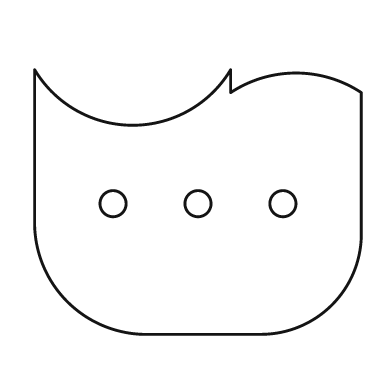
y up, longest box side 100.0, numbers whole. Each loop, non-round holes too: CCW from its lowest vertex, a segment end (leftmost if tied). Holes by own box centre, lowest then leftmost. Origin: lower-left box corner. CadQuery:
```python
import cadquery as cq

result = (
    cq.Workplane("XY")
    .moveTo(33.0, 0.0)
    .lineTo(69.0, 0.0)
    .threePointArc((91.0, 9.0), (100.0, 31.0))
    .lineTo(100.0, 74.0)
    .threePointArc((80.0, 80.0), (60.0, 74.0))
    .lineTo(60.0, 81.0)
    .threePointArc((30.0, 64.0), (0.0, 81.0))
    .lineTo(0.0, 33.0)
    .threePointArc((10.0, 10.0), (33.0, 0.0))
    .close()
    .moveTo(24.0, 40.0)
    .circle(4.0)
    .moveTo(50.0, 40.0)
    .circle(4.0)
    .moveTo(76.0, 40.0)
    .circle(4.0)
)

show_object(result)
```